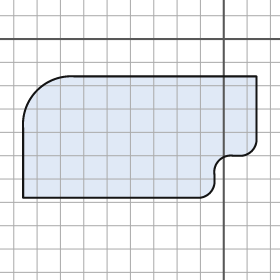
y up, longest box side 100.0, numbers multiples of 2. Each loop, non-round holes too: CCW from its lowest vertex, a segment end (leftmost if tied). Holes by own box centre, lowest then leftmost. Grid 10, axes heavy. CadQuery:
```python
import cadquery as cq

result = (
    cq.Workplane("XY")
    .moveTo(-86.0, -68.0)
    .lineTo(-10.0, -68.0)
    .threePointArc((-6.0, -66.0), (-4.0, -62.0))
    .lineTo(-4.0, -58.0)
    .threePointArc((-2.0, -52.0), (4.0, -50.0))
    .lineTo(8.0, -50.0)
    .threePointArc((12.0, -48.0), (14.0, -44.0))
    .lineTo(14.0, -16.0)
    .lineTo(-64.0, -16.0)
    .threePointArc((-80.0, -22.0), (-86.0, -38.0))
    .close()
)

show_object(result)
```